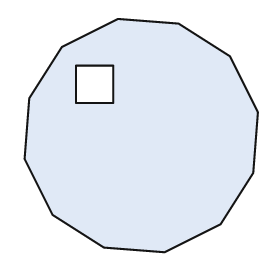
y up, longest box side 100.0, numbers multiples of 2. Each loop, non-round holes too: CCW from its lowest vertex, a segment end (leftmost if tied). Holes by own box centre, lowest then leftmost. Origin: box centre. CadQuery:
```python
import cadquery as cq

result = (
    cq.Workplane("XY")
    .moveTo(10.0, -50.0)
    .lineTo(34.0, -38.0)
    .lineTo(48.0, -16.0)
    .lineTo(50.0, 10.0)
    .lineTo(38.0, 34.0)
    .lineTo(16.0, 48.0)
    .lineTo(-10.0, 50.0)
    .lineTo(-34.0, 38.0)
    .lineTo(-48.0, 16.0)
    .lineTo(-50.0, -10.0)
    .lineTo(-38.0, -34.0)
    .lineTo(-16.0, -48.0)
    .close()
    .moveTo(-28.0, 14.0)
    .lineTo(-12.0, 14.0)
    .lineTo(-12.0, 30.0)
    .lineTo(-28.0, 30.0)
    .close()
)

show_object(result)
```